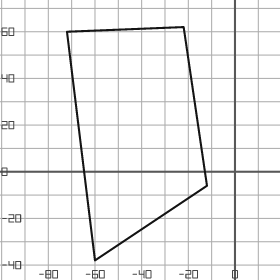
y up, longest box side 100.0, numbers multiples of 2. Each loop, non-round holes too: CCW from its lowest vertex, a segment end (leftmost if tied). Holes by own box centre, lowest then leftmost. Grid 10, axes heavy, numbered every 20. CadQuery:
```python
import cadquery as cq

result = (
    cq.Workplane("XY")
    .moveTo(-60.0, -38.0)
    .lineTo(-12.0, -6.0)
    .lineTo(-22.0, 62.0)
    .lineTo(-72.0, 60.0)
    .close()
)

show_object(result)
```